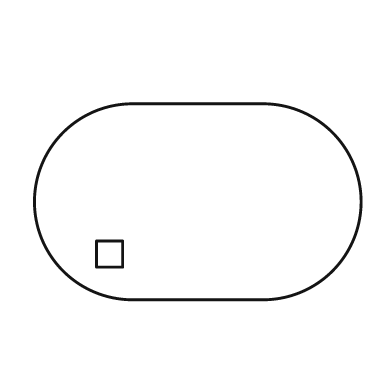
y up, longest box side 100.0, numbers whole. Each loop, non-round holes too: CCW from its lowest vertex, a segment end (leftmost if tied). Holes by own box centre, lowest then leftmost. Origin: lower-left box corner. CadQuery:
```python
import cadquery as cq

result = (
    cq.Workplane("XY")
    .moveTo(30.0, 0.0)
    .lineTo(70.0, 0.0)
    .threePointArc((100.0, 30.0), (70.0, 60.0))
    .lineTo(30.0, 60.0)
    .threePointArc((0.0, 30.0), (30.0, 0.0))
    .close()
    .moveTo(19.0, 10.0)
    .lineTo(27.0, 10.0)
    .lineTo(27.0, 18.0)
    .lineTo(19.0, 18.0)
    .close()
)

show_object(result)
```